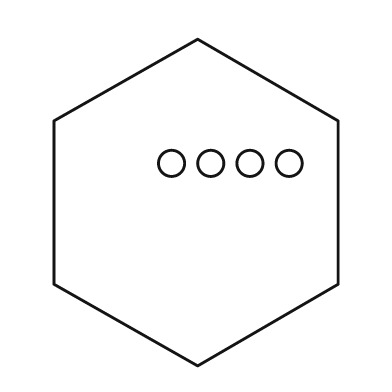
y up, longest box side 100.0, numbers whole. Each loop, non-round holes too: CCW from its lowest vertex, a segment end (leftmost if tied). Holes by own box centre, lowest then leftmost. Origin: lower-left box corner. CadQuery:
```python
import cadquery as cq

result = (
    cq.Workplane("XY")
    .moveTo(44.0, 0.0)
    .lineTo(87.0, 25.0)
    .lineTo(87.0, 75.0)
    .lineTo(44.0, 100.0)
    .lineTo(0.0, 75.0)
    .lineTo(0.0, 25.0)
    .close()
    .moveTo(36.0, 62.0)
    .circle(4.0)
    .moveTo(48.0, 62.0)
    .circle(4.0)
    .moveTo(60.0, 62.0)
    .circle(4.0)
    .moveTo(72.0, 62.0)
    .circle(4.0)
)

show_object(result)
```